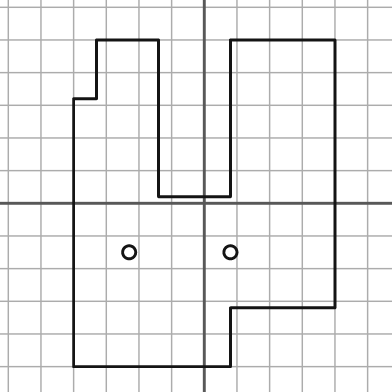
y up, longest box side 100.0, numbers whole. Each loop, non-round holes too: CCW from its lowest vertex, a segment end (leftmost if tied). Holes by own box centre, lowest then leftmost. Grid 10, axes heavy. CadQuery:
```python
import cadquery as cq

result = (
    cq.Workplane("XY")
    .moveTo(-40.0, -50.0)
    .lineTo(8.0, -50.0)
    .lineTo(8.0, -32.0)
    .lineTo(40.0, -32.0)
    .lineTo(40.0, 50.0)
    .lineTo(8.0, 50.0)
    .lineTo(8.0, 2.0)
    .lineTo(-14.0, 2.0)
    .lineTo(-14.0, 50.0)
    .lineTo(-33.0, 50.0)
    .lineTo(-33.0, 32.0)
    .lineTo(-40.0, 32.0)
    .close()
    .moveTo(-23.0, -15.0)
    .circle(2.0)
    .moveTo(8.0, -15.0)
    .circle(2.0)
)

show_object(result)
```